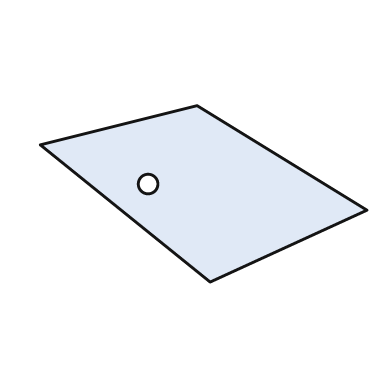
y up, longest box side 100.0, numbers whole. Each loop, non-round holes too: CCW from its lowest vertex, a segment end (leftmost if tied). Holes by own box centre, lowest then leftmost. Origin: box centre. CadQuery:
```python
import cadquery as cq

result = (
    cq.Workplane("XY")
    .moveTo(2.0, -27.0)
    .lineTo(50.0, -5.0)
    .lineTo(-2.0, 27.0)
    .lineTo(-50.0, 15.0)
    .close()
    .moveTo(-17.0, 3.0)
    .circle(3.0)
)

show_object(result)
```